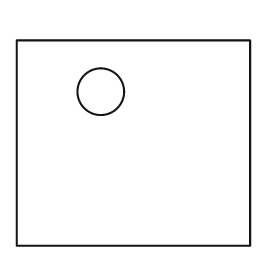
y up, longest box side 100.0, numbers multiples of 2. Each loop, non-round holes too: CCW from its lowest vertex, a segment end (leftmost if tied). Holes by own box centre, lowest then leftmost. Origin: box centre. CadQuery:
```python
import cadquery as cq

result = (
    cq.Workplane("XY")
    .moveTo(-50.0, -44.0)
    .lineTo(50.0, -44.0)
    .lineTo(50.0, 44.0)
    .lineTo(-50.0, 44.0)
    .close()
    .moveTo(-14.0, 22.0)
    .circle(10.0)
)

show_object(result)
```